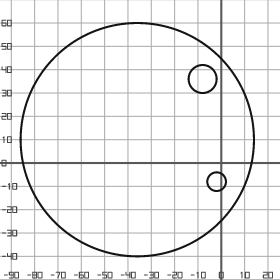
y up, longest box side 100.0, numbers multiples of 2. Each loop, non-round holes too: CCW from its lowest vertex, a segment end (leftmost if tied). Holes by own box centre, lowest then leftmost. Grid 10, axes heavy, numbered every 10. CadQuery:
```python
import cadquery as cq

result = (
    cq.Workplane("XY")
    .moveTo(-36.0, 10.0)
    .circle(50.0)
    .moveTo(-2.0, -8.0)
    .circle(4.0)
    .moveTo(-8.0, 36.0)
    .circle(6.0)
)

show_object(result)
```